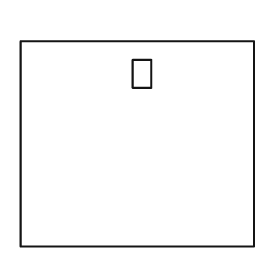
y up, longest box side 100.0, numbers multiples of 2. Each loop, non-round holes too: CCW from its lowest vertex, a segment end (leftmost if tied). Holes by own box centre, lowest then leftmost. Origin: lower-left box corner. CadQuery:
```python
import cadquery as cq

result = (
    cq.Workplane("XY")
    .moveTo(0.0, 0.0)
    .lineTo(100.0, 0.0)
    .lineTo(100.0, 88.0)
    .lineTo(0.0, 88.0)
    .close()
    .moveTo(48.0, 68.0)
    .lineTo(56.0, 68.0)
    .lineTo(56.0, 80.0)
    .lineTo(48.0, 80.0)
    .close()
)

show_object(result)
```